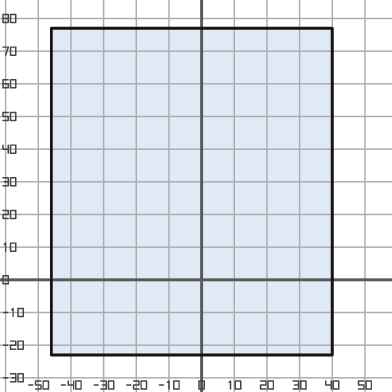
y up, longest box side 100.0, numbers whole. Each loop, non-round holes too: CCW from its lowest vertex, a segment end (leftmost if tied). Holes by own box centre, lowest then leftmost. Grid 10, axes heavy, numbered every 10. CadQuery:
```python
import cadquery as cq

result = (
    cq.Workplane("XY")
    .moveTo(-46.0, -23.0)
    .lineTo(40.0, -23.0)
    .lineTo(40.0, 77.0)
    .lineTo(-46.0, 77.0)
    .close()
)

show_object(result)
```